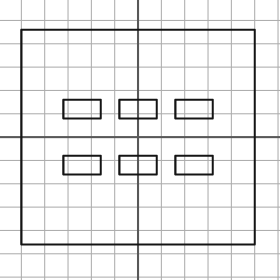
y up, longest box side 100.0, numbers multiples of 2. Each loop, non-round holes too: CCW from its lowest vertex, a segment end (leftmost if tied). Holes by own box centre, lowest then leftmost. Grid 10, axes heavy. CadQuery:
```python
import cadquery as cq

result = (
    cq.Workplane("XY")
    .moveTo(-50.0, -46.0)
    .lineTo(50.0, -46.0)
    .lineTo(50.0, 46.0)
    .lineTo(-50.0, 46.0)
    .close()
    .moveTo(-32.0, -16.0)
    .lineTo(-16.0, -16.0)
    .lineTo(-16.0, -8.0)
    .lineTo(-32.0, -8.0)
    .close()
    .moveTo(-8.0, -16.0)
    .lineTo(8.0, -16.0)
    .lineTo(8.0, -8.0)
    .lineTo(-8.0, -8.0)
    .close()
    .moveTo(16.0, -16.0)
    .lineTo(32.0, -16.0)
    .lineTo(32.0, -8.0)
    .lineTo(16.0, -8.0)
    .close()
    .moveTo(-32.0, 8.0)
    .lineTo(-16.0, 8.0)
    .lineTo(-16.0, 16.0)
    .lineTo(-32.0, 16.0)
    .close()
    .moveTo(-8.0, 8.0)
    .lineTo(8.0, 8.0)
    .lineTo(8.0, 16.0)
    .lineTo(-8.0, 16.0)
    .close()
    .moveTo(16.0, 8.0)
    .lineTo(32.0, 8.0)
    .lineTo(32.0, 16.0)
    .lineTo(16.0, 16.0)
    .close()
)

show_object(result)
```